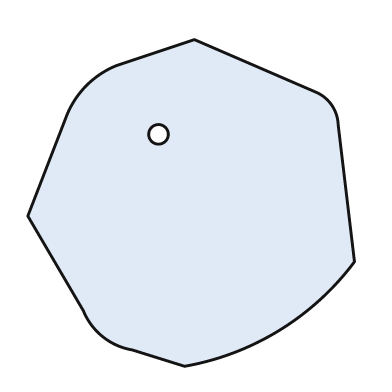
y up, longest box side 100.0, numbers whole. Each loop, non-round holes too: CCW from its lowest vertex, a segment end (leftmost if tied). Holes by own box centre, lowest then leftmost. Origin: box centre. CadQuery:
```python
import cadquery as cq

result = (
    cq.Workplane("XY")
    .moveTo(-2.0, -50.0)
    .threePointArc((27.0, -39.0), (50.0, -18.0))
    .lineTo(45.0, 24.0)
    .threePointArc((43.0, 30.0), (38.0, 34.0))
    .lineTo(1.0, 50.0)
    .lineTo(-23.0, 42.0)
    .threePointArc((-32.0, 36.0), (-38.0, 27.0))
    .lineTo(-50.0, -4.0)
    .lineTo(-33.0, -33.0)
    .threePointArc((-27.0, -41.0), (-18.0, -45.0))
    .close()
    .moveTo(-10.0, 21.0)
    .circle(3.0)
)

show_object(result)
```